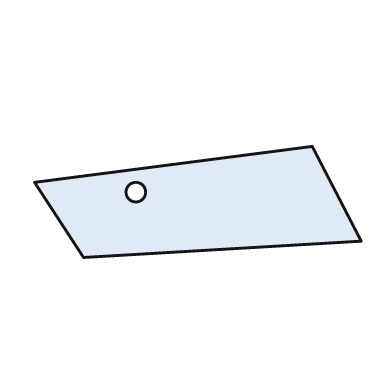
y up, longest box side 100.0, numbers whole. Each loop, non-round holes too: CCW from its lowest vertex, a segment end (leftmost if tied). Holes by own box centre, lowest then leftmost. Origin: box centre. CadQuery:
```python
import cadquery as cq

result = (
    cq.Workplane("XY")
    .moveTo(-35.0, -17.0)
    .lineTo(50.0, -12.0)
    .lineTo(35.0, 17.0)
    .lineTo(-50.0, 6.0)
    .close()
    .moveTo(-19.0, 3.0)
    .circle(3.0)
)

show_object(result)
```